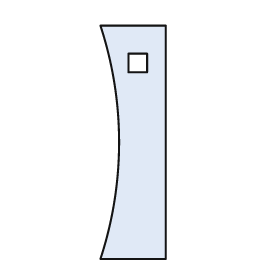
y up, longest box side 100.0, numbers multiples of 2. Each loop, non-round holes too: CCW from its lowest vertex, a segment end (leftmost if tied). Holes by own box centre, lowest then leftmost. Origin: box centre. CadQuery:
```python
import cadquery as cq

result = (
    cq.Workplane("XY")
    .moveTo(-14.0, -50.0)
    .lineTo(14.0, -50.0)
    .lineTo(14.0, 50.0)
    .lineTo(-14.0, 50.0)
    .threePointArc((-6.0, 0.0), (-14.0, -50.0))
    .close()
    .moveTo(-2.0, 30.0)
    .lineTo(6.0, 30.0)
    .lineTo(6.0, 38.0)
    .lineTo(-2.0, 38.0)
    .close()
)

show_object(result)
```